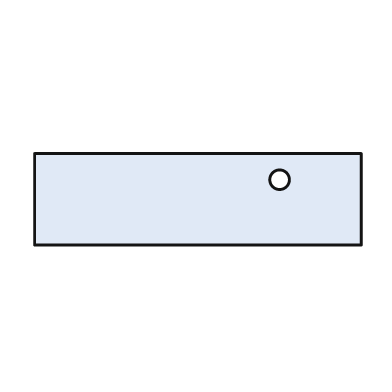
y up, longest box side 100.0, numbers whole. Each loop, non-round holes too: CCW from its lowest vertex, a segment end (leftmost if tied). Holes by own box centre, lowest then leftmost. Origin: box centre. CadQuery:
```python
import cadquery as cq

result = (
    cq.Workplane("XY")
    .moveTo(-50.0, -14.0)
    .lineTo(50.0, -14.0)
    .lineTo(50.0, 14.0)
    .lineTo(-50.0, 14.0)
    .close()
    .moveTo(25.0, 6.0)
    .circle(3.0)
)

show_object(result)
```